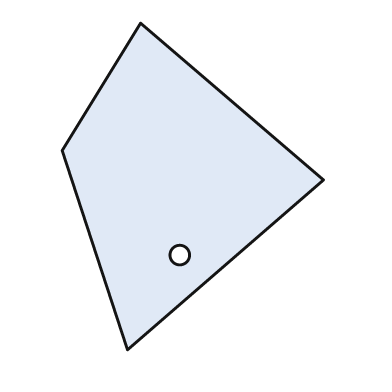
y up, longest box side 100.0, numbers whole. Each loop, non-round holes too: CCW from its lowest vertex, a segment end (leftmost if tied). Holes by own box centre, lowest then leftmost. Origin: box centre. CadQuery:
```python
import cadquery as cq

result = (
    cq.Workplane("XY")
    .moveTo(-20.0, -50.0)
    .lineTo(40.0, 2.0)
    .lineTo(-16.0, 50.0)
    .lineTo(-40.0, 11.0)
    .close()
    .moveTo(-4.0, -21.0)
    .circle(3.0)
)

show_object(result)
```